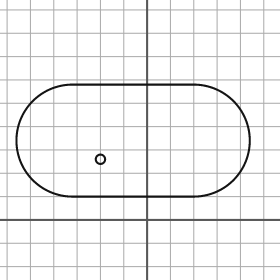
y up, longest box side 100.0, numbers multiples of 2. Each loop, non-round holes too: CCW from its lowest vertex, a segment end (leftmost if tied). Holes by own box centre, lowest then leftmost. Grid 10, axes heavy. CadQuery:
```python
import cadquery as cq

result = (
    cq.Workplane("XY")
    .moveTo(-32.0, 10.0)
    .lineTo(20.0, 10.0)
    .threePointArc((44.0, 34.0), (20.0, 58.0))
    .lineTo(-32.0, 58.0)
    .threePointArc((-56.0, 34.0), (-32.0, 10.0))
    .close()
    .moveTo(-20.0, 26.0)
    .circle(2.0)
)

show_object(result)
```